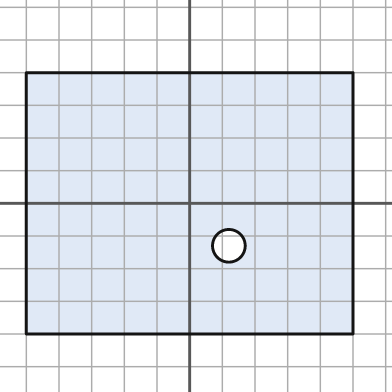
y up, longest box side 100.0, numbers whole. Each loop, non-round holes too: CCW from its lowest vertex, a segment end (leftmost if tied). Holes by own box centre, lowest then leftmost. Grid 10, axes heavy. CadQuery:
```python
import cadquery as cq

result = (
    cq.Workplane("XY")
    .moveTo(-50.0, -40.0)
    .lineTo(50.0, -40.0)
    .lineTo(50.0, 40.0)
    .lineTo(-50.0, 40.0)
    .close()
    .moveTo(12.0, -13.0)
    .circle(5.0)
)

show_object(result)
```